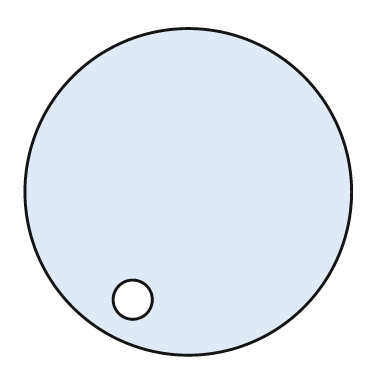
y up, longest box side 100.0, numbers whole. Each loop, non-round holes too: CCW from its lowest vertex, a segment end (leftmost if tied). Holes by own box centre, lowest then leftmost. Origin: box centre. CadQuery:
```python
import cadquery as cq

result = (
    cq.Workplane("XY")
    .moveTo(0.0, 0.0)
    .circle(50.0)
    .moveTo(-17.0, -33.0)
    .circle(6.0)
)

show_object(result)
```